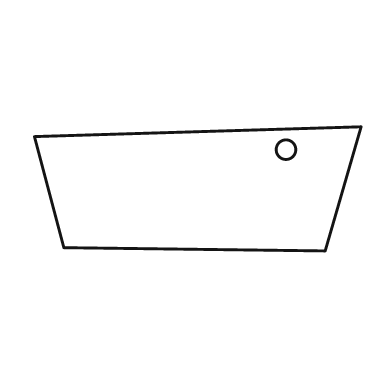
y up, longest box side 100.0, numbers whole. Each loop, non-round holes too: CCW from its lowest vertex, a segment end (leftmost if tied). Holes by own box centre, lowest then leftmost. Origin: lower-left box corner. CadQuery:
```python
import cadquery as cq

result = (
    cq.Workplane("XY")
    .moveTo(89.0, 0.0)
    .lineTo(100.0, 38.0)
    .lineTo(0.0, 35.0)
    .lineTo(9.0, 1.0)
    .close()
    .moveTo(77.0, 31.0)
    .circle(3.0)
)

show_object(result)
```